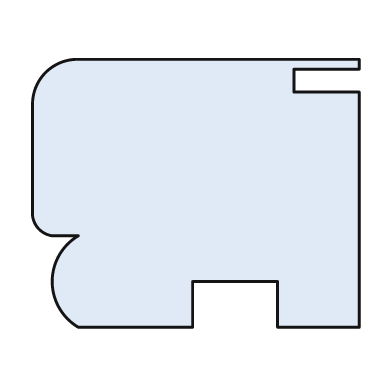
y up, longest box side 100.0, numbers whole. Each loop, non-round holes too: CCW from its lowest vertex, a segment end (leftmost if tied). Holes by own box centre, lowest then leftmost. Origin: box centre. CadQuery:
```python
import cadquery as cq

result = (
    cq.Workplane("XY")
    .moveTo(-36.0, -41.0)
    .lineTo(-1.0, -41.0)
    .lineTo(-1.0, -27.0)
    .lineTo(25.0, -27.0)
    .lineTo(25.0, -41.0)
    .lineTo(50.0, -41.0)
    .lineTo(50.0, 31.0)
    .lineTo(30.0, 31.0)
    .lineTo(30.0, 38.0)
    .lineTo(50.0, 38.0)
    .lineTo(50.0, 41.0)
    .lineTo(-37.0, 41.0)
    .threePointArc((-46.0, 37.0), (-50.0, 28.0))
    .lineTo(-50.0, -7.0)
    .threePointArc((-48.0, -11.0), (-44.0, -13.0))
    .lineTo(-36.0, -13.0)
    .threePointArc((-44.0, -27.0), (-36.0, -41.0))
    .close()
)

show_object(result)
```